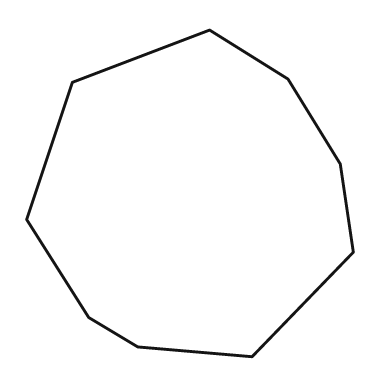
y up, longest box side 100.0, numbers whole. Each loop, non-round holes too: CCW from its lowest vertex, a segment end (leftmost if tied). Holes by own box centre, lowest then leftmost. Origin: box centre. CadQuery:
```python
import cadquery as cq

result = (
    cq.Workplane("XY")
    .moveTo(19.0, -50.0)
    .lineTo(50.0, -18.0)
    .lineTo(46.0, 9.0)
    .lineTo(30.0, 35.0)
    .lineTo(6.0, 50.0)
    .lineTo(-36.0, 34.0)
    .lineTo(-50.0, -8.0)
    .lineTo(-31.0, -38.0)
    .lineTo(-16.0, -47.0)
    .close()
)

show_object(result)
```